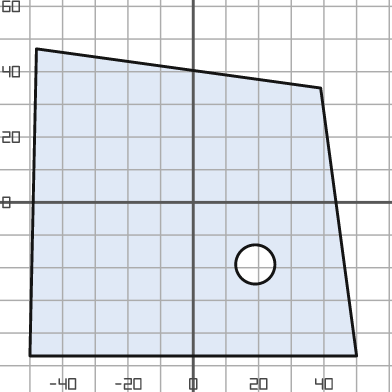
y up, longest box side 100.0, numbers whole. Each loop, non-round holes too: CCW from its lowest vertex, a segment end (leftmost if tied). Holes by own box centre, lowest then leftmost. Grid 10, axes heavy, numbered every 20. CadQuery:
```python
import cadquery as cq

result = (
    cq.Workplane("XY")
    .moveTo(-50.0, -47.0)
    .lineTo(50.0, -47.0)
    .lineTo(39.0, 35.0)
    .lineTo(-48.0, 47.0)
    .close()
    .moveTo(19.0, -19.0)
    .circle(6.0)
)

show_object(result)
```